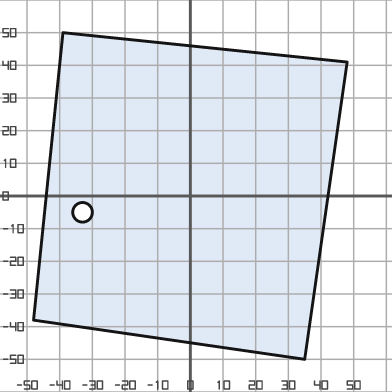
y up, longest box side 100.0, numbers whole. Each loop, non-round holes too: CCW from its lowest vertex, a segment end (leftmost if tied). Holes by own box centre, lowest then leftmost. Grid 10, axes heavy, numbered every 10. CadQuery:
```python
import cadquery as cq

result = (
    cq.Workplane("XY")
    .moveTo(35.0, -50.0)
    .lineTo(48.0, 41.0)
    .lineTo(-39.0, 50.0)
    .lineTo(-48.0, -38.0)
    .close()
    .moveTo(-33.0, -5.0)
    .circle(3.0)
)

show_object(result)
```